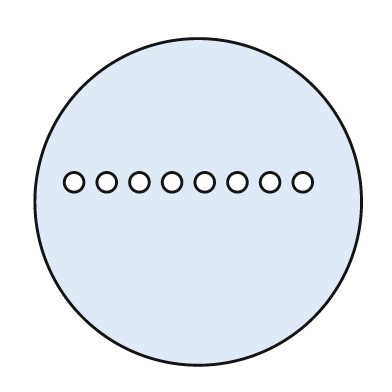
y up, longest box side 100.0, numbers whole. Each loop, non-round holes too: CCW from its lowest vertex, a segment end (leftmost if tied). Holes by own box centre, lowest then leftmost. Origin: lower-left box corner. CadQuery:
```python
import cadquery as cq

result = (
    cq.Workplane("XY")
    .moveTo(50.0, 50.0)
    .circle(50.0)
    .moveTo(12.0, 56.0)
    .circle(3.0)
    .moveTo(22.0, 56.0)
    .circle(3.0)
    .moveTo(32.0, 56.0)
    .circle(3.0)
    .moveTo(42.0, 56.0)
    .circle(3.0)
    .moveTo(52.0, 56.0)
    .circle(3.0)
    .moveTo(62.0, 56.0)
    .circle(3.0)
    .moveTo(72.0, 56.0)
    .circle(3.0)
    .moveTo(82.0, 56.0)
    .circle(3.0)
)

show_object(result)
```